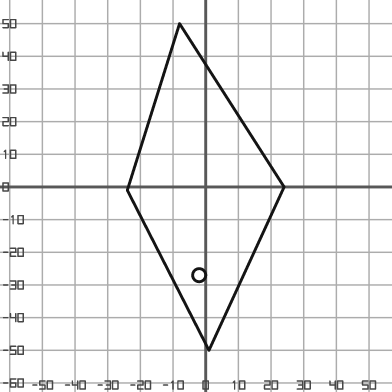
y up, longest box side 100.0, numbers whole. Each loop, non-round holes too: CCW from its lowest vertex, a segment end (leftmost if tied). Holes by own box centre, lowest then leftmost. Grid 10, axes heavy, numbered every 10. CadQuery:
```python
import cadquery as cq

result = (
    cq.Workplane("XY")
    .moveTo(1.0, -50.0)
    .lineTo(24.0, 0.0)
    .lineTo(-8.0, 50.0)
    .lineTo(-24.0, -1.0)
    .close()
    .moveTo(-2.0, -27.0)
    .circle(2.0)
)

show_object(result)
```